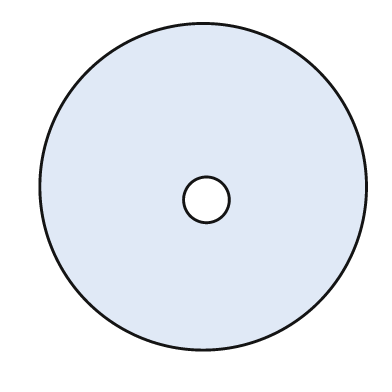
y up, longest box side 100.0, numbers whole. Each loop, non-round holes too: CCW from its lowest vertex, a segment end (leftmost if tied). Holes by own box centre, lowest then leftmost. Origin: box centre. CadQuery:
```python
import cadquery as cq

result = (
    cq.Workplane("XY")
    .moveTo(0.0, 0.0)
    .circle(50.0)
    .moveTo(1.0, -4.0)
    .circle(7.0)
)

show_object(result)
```